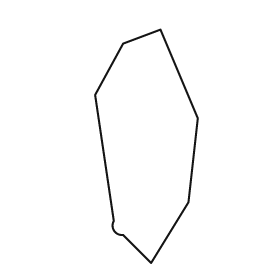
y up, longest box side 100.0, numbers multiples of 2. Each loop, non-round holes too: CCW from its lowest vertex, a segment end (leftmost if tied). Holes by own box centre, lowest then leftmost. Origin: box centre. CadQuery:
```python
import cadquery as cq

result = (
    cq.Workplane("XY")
    .moveTo(2.0, -50.0)
    .lineTo(18.0, -24.0)
    .lineTo(22.0, 12.0)
    .lineTo(6.0, 50.0)
    .lineTo(-10.0, 44.0)
    .lineTo(-22.0, 22.0)
    .lineTo(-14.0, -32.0)
    .threePointArc((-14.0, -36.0), (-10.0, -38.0))
    .close()
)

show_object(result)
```